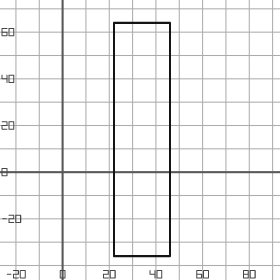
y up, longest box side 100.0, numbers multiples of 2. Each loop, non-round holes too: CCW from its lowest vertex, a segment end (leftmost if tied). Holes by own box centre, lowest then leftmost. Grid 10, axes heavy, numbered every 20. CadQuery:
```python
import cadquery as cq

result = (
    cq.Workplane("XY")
    .moveTo(22.0, -36.0)
    .lineTo(46.0, -36.0)
    .lineTo(46.0, 64.0)
    .lineTo(22.0, 64.0)
    .close()
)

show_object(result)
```